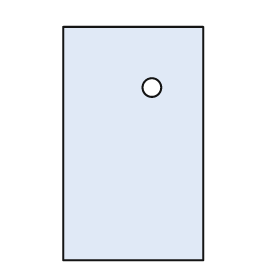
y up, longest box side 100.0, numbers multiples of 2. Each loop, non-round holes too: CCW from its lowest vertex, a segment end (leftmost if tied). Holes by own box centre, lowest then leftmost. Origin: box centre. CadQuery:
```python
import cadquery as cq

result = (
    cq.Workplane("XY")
    .moveTo(-30.0, -50.0)
    .lineTo(30.0, -50.0)
    .lineTo(30.0, 50.0)
    .lineTo(-30.0, 50.0)
    .close()
    .moveTo(8.0, 24.0)
    .circle(4.0)
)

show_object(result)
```